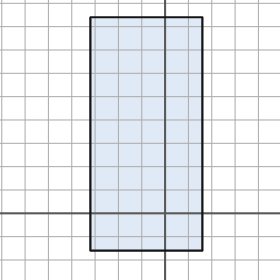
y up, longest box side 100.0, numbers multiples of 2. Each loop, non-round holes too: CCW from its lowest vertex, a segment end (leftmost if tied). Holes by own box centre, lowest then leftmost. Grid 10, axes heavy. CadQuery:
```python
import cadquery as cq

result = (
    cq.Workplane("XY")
    .moveTo(-32.0, -16.0)
    .lineTo(16.0, -16.0)
    .lineTo(16.0, 84.0)
    .lineTo(-32.0, 84.0)
    .close()
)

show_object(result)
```